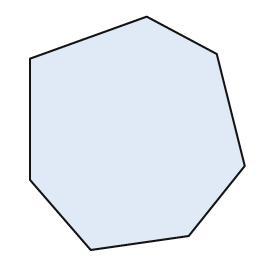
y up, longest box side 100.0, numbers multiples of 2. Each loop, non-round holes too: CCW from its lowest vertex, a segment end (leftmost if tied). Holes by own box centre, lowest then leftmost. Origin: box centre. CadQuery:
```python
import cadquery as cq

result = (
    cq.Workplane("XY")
    .moveTo(-20.0, -50.0)
    .lineTo(22.0, -44.0)
    .lineTo(46.0, -14.0)
    .lineTo(34.0, 34.0)
    .lineTo(4.0, 50.0)
    .lineTo(-46.0, 32.0)
    .lineTo(-46.0, -20.0)
    .close()
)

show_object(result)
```